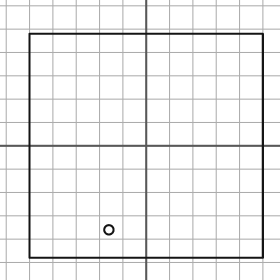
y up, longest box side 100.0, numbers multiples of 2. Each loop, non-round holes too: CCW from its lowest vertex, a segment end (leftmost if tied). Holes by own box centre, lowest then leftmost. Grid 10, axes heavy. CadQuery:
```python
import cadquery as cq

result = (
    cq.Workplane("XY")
    .moveTo(-50.0, -48.0)
    .lineTo(50.0, -48.0)
    .lineTo(50.0, 48.0)
    .lineTo(-50.0, 48.0)
    .close()
    .moveTo(-16.0, -36.0)
    .circle(2.0)
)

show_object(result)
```